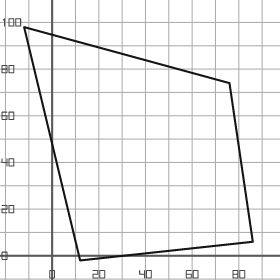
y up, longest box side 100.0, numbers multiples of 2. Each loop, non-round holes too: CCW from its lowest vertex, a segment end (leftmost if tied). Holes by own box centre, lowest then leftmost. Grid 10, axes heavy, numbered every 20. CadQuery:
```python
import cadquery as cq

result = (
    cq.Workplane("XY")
    .moveTo(12.0, -2.0)
    .lineTo(86.0, 6.0)
    .lineTo(76.0, 74.0)
    .lineTo(-12.0, 98.0)
    .close()
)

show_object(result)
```